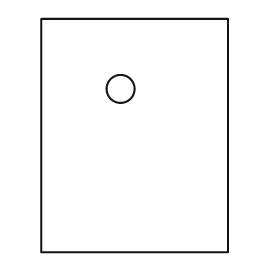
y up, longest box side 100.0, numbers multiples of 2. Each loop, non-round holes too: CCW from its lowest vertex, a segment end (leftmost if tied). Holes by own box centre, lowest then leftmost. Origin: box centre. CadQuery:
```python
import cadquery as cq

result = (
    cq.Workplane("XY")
    .moveTo(-40.0, -50.0)
    .lineTo(40.0, -50.0)
    .lineTo(40.0, 50.0)
    .lineTo(-40.0, 50.0)
    .close()
    .moveTo(-6.0, 20.0)
    .circle(6.0)
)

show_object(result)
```